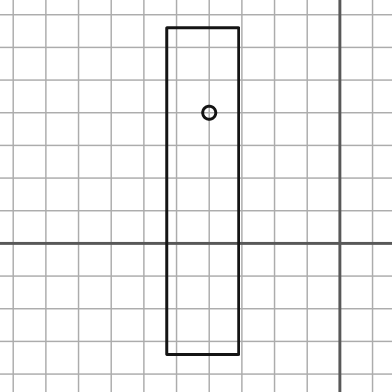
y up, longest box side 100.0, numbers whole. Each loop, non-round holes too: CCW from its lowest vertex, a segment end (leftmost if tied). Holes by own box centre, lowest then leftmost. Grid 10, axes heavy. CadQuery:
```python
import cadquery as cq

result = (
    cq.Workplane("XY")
    .moveTo(-53.0, -34.0)
    .lineTo(-31.0, -34.0)
    .lineTo(-31.0, 66.0)
    .lineTo(-53.0, 66.0)
    .close()
    .moveTo(-40.0, 40.0)
    .circle(2.0)
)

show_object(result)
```